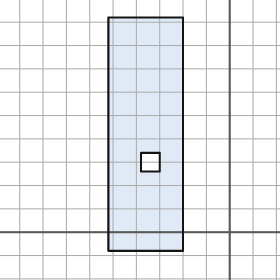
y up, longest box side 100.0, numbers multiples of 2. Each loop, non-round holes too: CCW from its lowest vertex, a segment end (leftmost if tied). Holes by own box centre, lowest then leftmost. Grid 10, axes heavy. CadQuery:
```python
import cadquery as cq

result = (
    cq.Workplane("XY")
    .moveTo(-52.0, -8.0)
    .lineTo(-20.0, -8.0)
    .lineTo(-20.0, 92.0)
    .lineTo(-52.0, 92.0)
    .close()
    .moveTo(-38.0, 26.0)
    .lineTo(-30.0, 26.0)
    .lineTo(-30.0, 34.0)
    .lineTo(-38.0, 34.0)
    .close()
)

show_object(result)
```